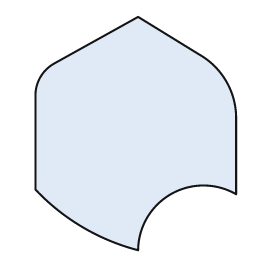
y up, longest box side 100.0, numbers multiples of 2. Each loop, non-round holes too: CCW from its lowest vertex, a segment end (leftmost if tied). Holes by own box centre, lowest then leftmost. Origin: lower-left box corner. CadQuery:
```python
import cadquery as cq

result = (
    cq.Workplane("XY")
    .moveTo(44.0, 0.0)
    .threePointArc((58.0, 24.0), (86.0, 24.0))
    .lineTo(86.0, 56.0)
    .threePointArc((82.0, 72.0), (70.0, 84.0))
    .lineTo(44.0, 100.0)
    .lineTo(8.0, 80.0)
    .threePointArc((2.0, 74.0), (0.0, 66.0))
    .lineTo(0.0, 26.0)
    .threePointArc((20.0, 10.0), (44.0, 0.0))
    .close()
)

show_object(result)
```